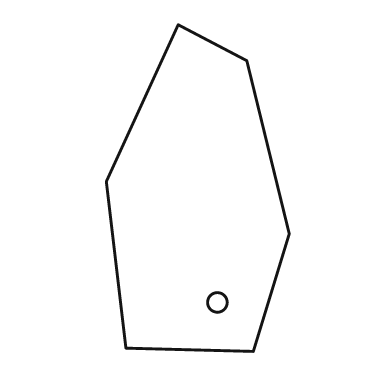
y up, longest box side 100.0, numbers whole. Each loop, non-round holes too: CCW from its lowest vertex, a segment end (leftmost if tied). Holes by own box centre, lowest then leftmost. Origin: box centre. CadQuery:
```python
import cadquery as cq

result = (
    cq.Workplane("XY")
    .moveTo(17.0, -50.0)
    .lineTo(28.0, -14.0)
    .lineTo(15.0, 39.0)
    .lineTo(-6.0, 50.0)
    .lineTo(-28.0, 2.0)
    .lineTo(-22.0, -49.0)
    .close()
    .moveTo(6.0, -35.0)
    .circle(3.0)
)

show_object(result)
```